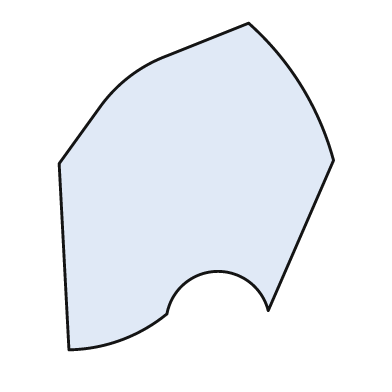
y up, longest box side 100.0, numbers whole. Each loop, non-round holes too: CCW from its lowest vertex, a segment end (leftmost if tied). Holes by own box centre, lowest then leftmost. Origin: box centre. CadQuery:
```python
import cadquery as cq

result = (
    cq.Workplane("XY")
    .moveTo(-39.0, -50.0)
    .threePointArc((-23.0, -47.0), (-9.0, -39.0))
    .threePointArc((6.0, -26.0), (22.0, -38.0))
    .lineTo(42.0, 8.0)
    .threePointArc((32.0, 31.0), (16.0, 50.0))
    .lineTo(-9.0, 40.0)
    .threePointArc((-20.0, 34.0), (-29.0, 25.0))
    .lineTo(-42.0, 7.0)
    .close()
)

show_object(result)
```